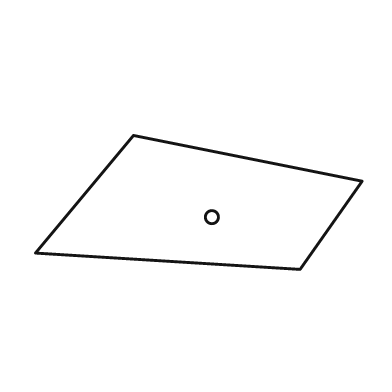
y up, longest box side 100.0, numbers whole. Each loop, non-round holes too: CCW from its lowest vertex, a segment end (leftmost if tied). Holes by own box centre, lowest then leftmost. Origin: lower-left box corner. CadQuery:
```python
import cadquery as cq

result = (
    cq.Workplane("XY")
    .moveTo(81.0, 0.0)
    .lineTo(100.0, 27.0)
    .lineTo(30.0, 41.0)
    .lineTo(0.0, 5.0)
    .close()
    .moveTo(54.0, 16.0)
    .circle(2.0)
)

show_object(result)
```